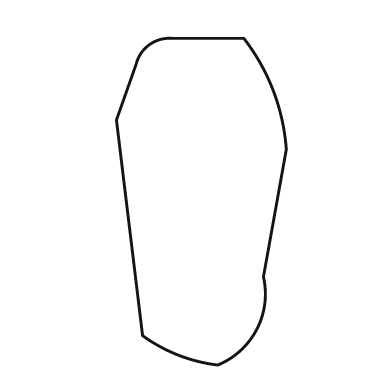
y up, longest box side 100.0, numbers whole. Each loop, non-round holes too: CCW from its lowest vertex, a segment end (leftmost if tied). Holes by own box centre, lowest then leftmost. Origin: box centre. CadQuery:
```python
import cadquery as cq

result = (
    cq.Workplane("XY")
    .moveTo(5.0, -50.0)
    .threePointArc((17.0, -39.0), (19.0, -23.0))
    .lineTo(26.0, 16.0)
    .threePointArc((22.0, 34.0), (13.0, 50.0))
    .lineTo(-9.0, 50.0)
    .threePointArc((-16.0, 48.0), (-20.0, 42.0))
    .lineTo(-26.0, 25.0)
    .lineTo(-18.0, -41.0)
    .threePointArc((-7.0, -47.0), (5.0, -50.0))
    .close()
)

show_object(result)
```